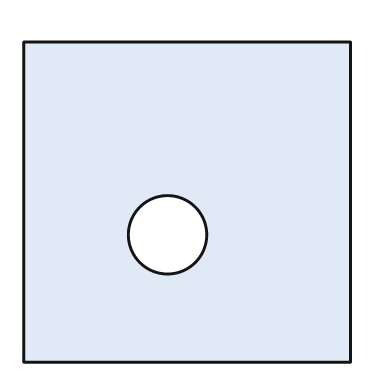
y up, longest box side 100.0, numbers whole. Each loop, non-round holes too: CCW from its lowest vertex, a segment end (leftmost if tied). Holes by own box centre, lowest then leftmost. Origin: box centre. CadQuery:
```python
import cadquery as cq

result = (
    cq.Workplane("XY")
    .moveTo(-50.0, -49.0)
    .lineTo(50.0, -49.0)
    .lineTo(50.0, 49.0)
    .lineTo(-50.0, 49.0)
    .close()
    .moveTo(-6.0, -10.0)
    .circle(12.0)
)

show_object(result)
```